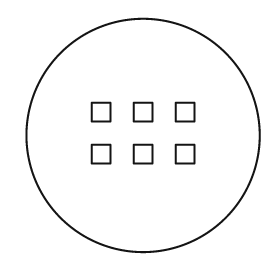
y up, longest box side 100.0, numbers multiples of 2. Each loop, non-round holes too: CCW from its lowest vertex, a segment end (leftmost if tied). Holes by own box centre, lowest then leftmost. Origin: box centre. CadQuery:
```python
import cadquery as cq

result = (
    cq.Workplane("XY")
    .moveTo(0.0, 0.0)
    .circle(50.0)
    .moveTo(-22.0, -12.0)
    .lineTo(-14.0, -12.0)
    .lineTo(-14.0, -4.0)
    .lineTo(-22.0, -4.0)
    .close()
    .moveTo(-4.0, -12.0)
    .lineTo(4.0, -12.0)
    .lineTo(4.0, -4.0)
    .lineTo(-4.0, -4.0)
    .close()
    .moveTo(14.0, -12.0)
    .lineTo(22.0, -12.0)
    .lineTo(22.0, -4.0)
    .lineTo(14.0, -4.0)
    .close()
    .moveTo(-22.0, 6.0)
    .lineTo(-14.0, 6.0)
    .lineTo(-14.0, 14.0)
    .lineTo(-22.0, 14.0)
    .close()
    .moveTo(-4.0, 6.0)
    .lineTo(4.0, 6.0)
    .lineTo(4.0, 14.0)
    .lineTo(-4.0, 14.0)
    .close()
    .moveTo(14.0, 6.0)
    .lineTo(22.0, 6.0)
    .lineTo(22.0, 14.0)
    .lineTo(14.0, 14.0)
    .close()
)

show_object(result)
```